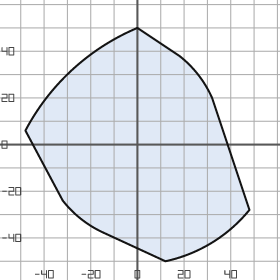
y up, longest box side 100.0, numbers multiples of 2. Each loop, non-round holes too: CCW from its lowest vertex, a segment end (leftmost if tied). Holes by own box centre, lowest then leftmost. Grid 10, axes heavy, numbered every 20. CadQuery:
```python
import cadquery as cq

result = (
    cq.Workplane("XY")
    .moveTo(12.0, -50.0)
    .threePointArc((32.0, -42.0), (48.0, -28.0))
    .lineTo(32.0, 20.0)
    .threePointArc((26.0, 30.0), (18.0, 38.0))
    .lineTo(0.0, 50.0)
    .threePointArc((-28.0, 32.0), (-48.0, 6.0))
    .lineTo(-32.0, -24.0)
    .threePointArc((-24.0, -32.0), (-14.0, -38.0))
    .close()
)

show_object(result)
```